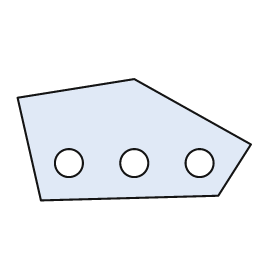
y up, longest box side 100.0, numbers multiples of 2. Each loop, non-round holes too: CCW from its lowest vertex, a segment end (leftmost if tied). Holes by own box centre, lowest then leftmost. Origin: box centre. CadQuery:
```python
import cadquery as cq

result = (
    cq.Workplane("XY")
    .moveTo(-40.0, -26.0)
    .lineTo(36.0, -24.0)
    .lineTo(50.0, -2.0)
    .lineTo(0.0, 26.0)
    .lineTo(-50.0, 18.0)
    .close()
    .moveTo(-28.0, -10.0)
    .circle(6.0)
    .moveTo(0.0, -10.0)
    .circle(6.0)
    .moveTo(28.0, -10.0)
    .circle(6.0)
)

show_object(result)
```